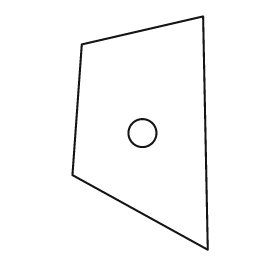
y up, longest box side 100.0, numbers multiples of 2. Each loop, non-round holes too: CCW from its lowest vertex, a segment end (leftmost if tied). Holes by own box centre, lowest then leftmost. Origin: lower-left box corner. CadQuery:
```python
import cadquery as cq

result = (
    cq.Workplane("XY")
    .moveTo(58.0, 0.0)
    .lineTo(56.0, 100.0)
    .lineTo(4.0, 88.0)
    .lineTo(0.0, 32.0)
    .close()
    .moveTo(30.0, 50.0)
    .circle(6.0)
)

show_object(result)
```